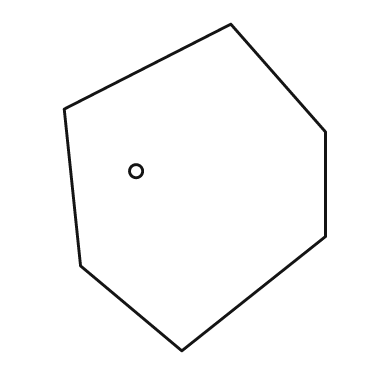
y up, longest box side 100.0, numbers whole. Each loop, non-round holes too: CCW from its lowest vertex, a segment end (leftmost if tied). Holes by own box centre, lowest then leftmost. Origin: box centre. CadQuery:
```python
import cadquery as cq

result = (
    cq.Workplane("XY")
    .moveTo(-4.0, -50.0)
    .lineTo(40.0, -15.0)
    .lineTo(40.0, 17.0)
    .lineTo(11.0, 50.0)
    .lineTo(-40.0, 24.0)
    .lineTo(-35.0, -24.0)
    .close()
    .moveTo(-18.0, 5.0)
    .circle(2.0)
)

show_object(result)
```